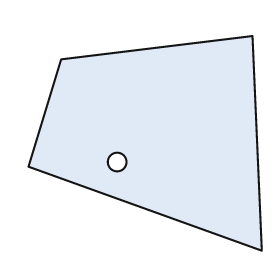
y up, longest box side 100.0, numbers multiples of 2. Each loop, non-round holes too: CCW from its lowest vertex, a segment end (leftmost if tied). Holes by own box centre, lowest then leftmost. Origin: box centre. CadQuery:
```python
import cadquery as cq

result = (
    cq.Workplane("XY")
    .moveTo(50.0, -46.0)
    .lineTo(46.0, 46.0)
    .lineTo(-36.0, 36.0)
    .lineTo(-50.0, -10.0)
    .close()
    .moveTo(-12.0, -8.0)
    .circle(4.0)
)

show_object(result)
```